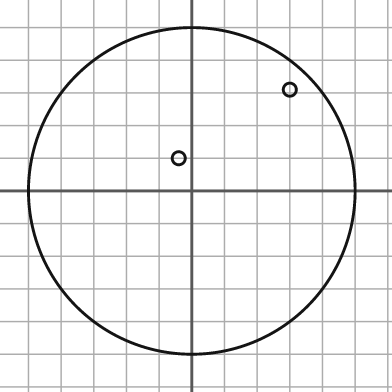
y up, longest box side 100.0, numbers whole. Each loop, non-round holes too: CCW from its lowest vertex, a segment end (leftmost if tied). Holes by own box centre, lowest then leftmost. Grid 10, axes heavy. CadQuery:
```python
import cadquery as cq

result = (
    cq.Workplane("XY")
    .moveTo(0.0, 0.0)
    .circle(50.0)
    .moveTo(-4.0, 10.0)
    .circle(2.0)
    .moveTo(30.0, 31.0)
    .circle(2.0)
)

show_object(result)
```